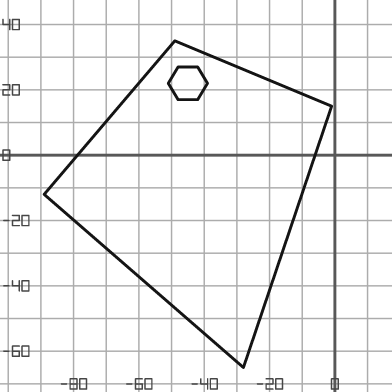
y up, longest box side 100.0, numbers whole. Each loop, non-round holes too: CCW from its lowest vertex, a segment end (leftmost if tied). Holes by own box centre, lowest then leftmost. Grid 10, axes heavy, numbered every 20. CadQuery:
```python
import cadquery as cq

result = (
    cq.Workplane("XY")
    .moveTo(-28.0, -65.0)
    .lineTo(-1.0, 15.0)
    .lineTo(-49.0, 35.0)
    .lineTo(-89.0, -12.0)
    .close()
    .moveTo(-48.0, 17.0)
    .lineTo(-42.0, 17.0)
    .lineTo(-39.0, 22.0)
    .lineTo(-42.0, 27.0)
    .lineTo(-48.0, 27.0)
    .lineTo(-51.0, 22.0)
    .close()
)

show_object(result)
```